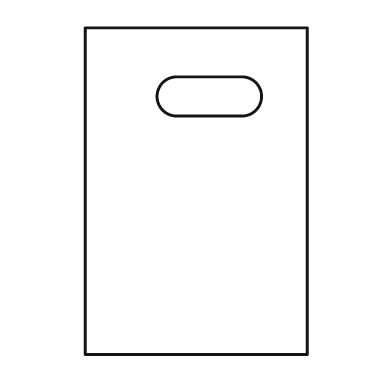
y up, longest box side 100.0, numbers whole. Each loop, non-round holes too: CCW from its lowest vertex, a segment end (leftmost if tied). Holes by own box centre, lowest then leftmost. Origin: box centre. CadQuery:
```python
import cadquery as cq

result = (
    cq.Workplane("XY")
    .moveTo(-34.0, -50.0)
    .lineTo(34.0, -50.0)
    .lineTo(34.0, 50.0)
    .lineTo(-34.0, 50.0)
    .close()
    .moveTo(-6.0, 23.0)
    .lineTo(14.0, 23.0)
    .threePointArc((20.0, 29.0), (14.0, 35.0))
    .lineTo(-6.0, 35.0)
    .threePointArc((-12.0, 29.0), (-6.0, 23.0))
    .close()
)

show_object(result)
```